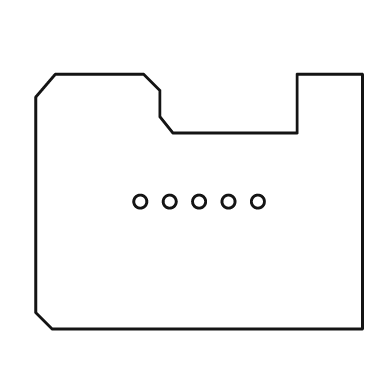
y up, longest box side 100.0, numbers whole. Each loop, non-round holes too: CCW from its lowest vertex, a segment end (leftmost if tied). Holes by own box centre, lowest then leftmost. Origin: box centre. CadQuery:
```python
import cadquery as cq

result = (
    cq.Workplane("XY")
    .moveTo(-45.0, -39.0)
    .lineTo(50.0, -39.0)
    .lineTo(50.0, 39.0)
    .lineTo(30.0, 39.0)
    .lineTo(30.0, 21.0)
    .lineTo(-8.0, 21.0)
    .lineTo(-12.0, 26.0)
    .lineTo(-12.0, 34.0)
    .lineTo(-17.0, 39.0)
    .lineTo(-44.0, 39.0)
    .lineTo(-50.0, 32.0)
    .lineTo(-50.0, -34.0)
    .close()
    .moveTo(-18.0, 0.0)
    .circle(2.0)
    .moveTo(-9.0, 0.0)
    .circle(2.0)
    .moveTo(0.0, 0.0)
    .circle(2.0)
    .moveTo(9.0, 0.0)
    .circle(2.0)
    .moveTo(18.0, 0.0)
    .circle(2.0)
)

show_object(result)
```